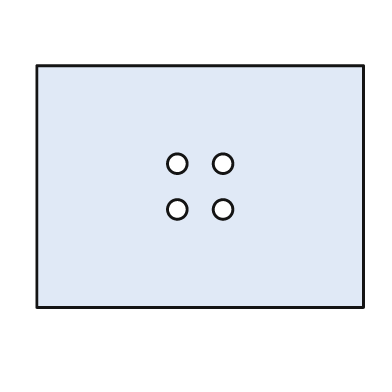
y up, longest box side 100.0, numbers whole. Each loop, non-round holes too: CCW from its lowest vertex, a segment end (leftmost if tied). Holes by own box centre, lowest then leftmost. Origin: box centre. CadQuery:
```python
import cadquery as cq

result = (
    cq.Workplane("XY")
    .moveTo(-50.0, -37.0)
    .lineTo(50.0, -37.0)
    .lineTo(50.0, 37.0)
    .lineTo(-50.0, 37.0)
    .close()
    .moveTo(-7.0, -7.0)
    .circle(3.0)
    .moveTo(7.0, -7.0)
    .circle(3.0)
    .moveTo(-7.0, 7.0)
    .circle(3.0)
    .moveTo(7.0, 7.0)
    .circle(3.0)
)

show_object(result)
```